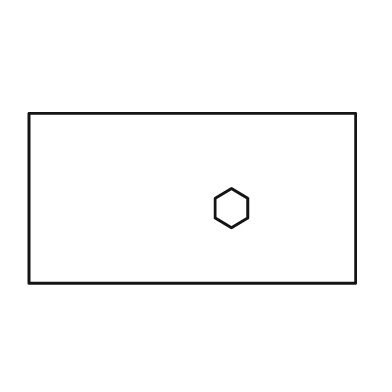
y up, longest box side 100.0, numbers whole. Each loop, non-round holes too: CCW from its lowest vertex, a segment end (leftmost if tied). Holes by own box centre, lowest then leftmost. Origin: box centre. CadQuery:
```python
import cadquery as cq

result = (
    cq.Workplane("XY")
    .moveTo(-50.0, -26.0)
    .lineTo(50.0, -26.0)
    .lineTo(50.0, 26.0)
    .lineTo(-50.0, 26.0)
    .close()
    .moveTo(12.0, -9.0)
    .lineTo(17.0, -6.0)
    .lineTo(17.0, 0.0)
    .lineTo(12.0, 3.0)
    .lineTo(7.0, 0.0)
    .lineTo(7.0, -6.0)
    .close()
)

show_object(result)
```